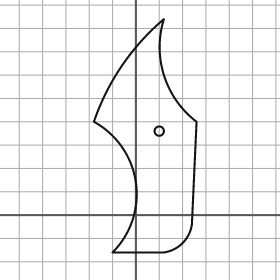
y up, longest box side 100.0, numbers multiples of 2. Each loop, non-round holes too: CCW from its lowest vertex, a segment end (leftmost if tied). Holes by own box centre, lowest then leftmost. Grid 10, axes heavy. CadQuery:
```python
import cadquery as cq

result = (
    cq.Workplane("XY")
    .moveTo(-10.0, -16.0)
    .lineTo(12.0, -16.0)
    .threePointArc((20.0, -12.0), (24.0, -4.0))
    .lineTo(26.0, 40.0)
    .threePointArc((12.0, 60.0), (12.0, 84.0))
    .threePointArc((-6.0, 64.0), (-18.0, 40.0))
    .threePointArc((0.0, 14.0), (-10.0, -16.0))
    .close()
    .moveTo(10.0, 36.0)
    .circle(2.0)
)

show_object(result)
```